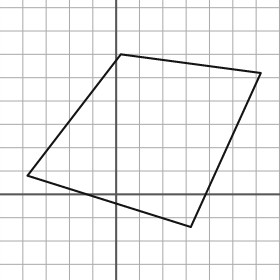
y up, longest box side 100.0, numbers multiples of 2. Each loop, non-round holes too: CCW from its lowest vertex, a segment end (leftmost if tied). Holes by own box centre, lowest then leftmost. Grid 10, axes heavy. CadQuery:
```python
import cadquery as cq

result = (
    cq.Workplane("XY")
    .moveTo(32.0, -14.0)
    .lineTo(62.0, 52.0)
    .lineTo(2.0, 60.0)
    .lineTo(-38.0, 8.0)
    .close()
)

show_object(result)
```